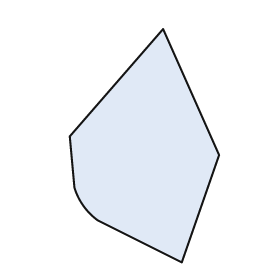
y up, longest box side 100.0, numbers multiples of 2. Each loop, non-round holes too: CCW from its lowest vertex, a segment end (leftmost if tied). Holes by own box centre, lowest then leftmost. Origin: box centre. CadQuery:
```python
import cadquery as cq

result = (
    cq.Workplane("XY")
    .moveTo(16.0, -50.0)
    .lineTo(32.0, -4.0)
    .lineTo(8.0, 50.0)
    .lineTo(-32.0, 4.0)
    .lineTo(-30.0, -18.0)
    .threePointArc((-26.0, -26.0), (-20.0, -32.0))
    .close()
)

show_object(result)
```